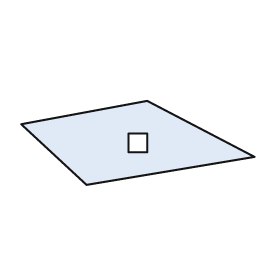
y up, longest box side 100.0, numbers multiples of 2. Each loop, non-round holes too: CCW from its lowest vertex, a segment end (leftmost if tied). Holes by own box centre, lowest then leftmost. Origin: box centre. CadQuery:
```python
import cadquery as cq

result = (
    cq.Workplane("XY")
    .moveTo(-22.0, -18.0)
    .lineTo(50.0, -6.0)
    .lineTo(4.0, 18.0)
    .lineTo(-50.0, 8.0)
    .close()
    .moveTo(-4.0, -4.0)
    .lineTo(4.0, -4.0)
    .lineTo(4.0, 4.0)
    .lineTo(-4.0, 4.0)
    .close()
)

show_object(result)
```